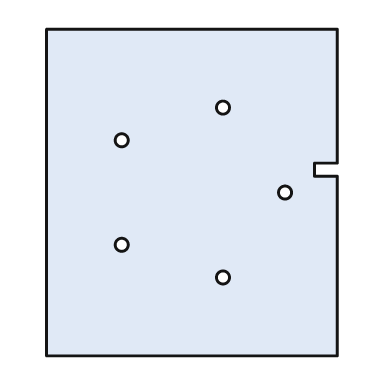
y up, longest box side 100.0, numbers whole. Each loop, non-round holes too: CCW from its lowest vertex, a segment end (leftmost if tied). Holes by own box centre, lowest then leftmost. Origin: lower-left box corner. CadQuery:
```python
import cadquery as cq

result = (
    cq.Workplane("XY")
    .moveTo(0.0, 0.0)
    .lineTo(89.0, 0.0)
    .lineTo(89.0, 55.0)
    .lineTo(82.0, 55.0)
    .lineTo(82.0, 59.0)
    .lineTo(89.0, 59.0)
    .lineTo(89.0, 100.0)
    .lineTo(0.0, 100.0)
    .close()
    .moveTo(54.0, 24.0)
    .circle(2.0)
    .moveTo(23.0, 34.0)
    .circle(2.0)
    .moveTo(73.0, 50.0)
    .circle(2.0)
    .moveTo(23.0, 66.0)
    .circle(2.0)
    .moveTo(54.0, 76.0)
    .circle(2.0)
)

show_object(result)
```